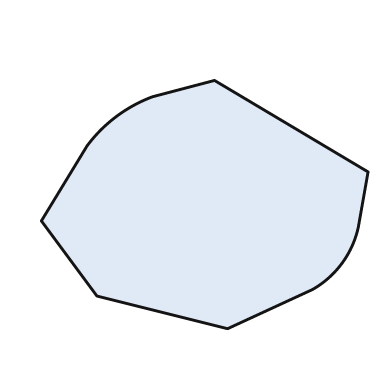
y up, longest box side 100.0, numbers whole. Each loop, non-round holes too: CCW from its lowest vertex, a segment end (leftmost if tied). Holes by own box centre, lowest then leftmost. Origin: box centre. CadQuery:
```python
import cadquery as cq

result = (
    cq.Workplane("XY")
    .moveTo(7.0, -38.0)
    .lineTo(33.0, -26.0)
    .threePointArc((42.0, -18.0), (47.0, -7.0))
    .lineTo(50.0, 10.0)
    .lineTo(3.0, 38.0)
    .lineTo(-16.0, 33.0)
    .threePointArc((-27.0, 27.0), (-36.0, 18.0))
    .lineTo(-50.0, -5.0)
    .lineTo(-33.0, -28.0)
    .close()
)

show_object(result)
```